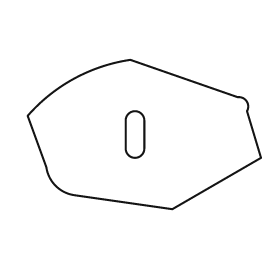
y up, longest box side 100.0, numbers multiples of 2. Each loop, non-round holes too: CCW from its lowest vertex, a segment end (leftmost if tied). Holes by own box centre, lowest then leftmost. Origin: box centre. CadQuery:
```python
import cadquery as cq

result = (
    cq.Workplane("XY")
    .moveTo(12.0, -32.0)
    .lineTo(50.0, -10.0)
    .lineTo(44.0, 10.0)
    .threePointArc((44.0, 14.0), (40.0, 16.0))
    .lineTo(-6.0, 32.0)
    .threePointArc((-30.0, 24.0), (-50.0, 8.0))
    .lineTo(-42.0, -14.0)
    .threePointArc((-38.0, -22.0), (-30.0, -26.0))
    .close()
    .moveTo(-8.0, -6.0)
    .threePointArc((-4.0, -10.0), (0.0, -6.0))
    .lineTo(0.0, 6.0)
    .threePointArc((-4.0, 10.0), (-8.0, 6.0))
    .close()
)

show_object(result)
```